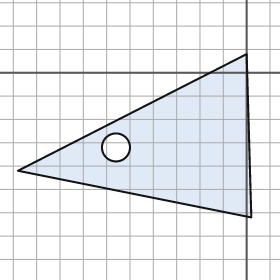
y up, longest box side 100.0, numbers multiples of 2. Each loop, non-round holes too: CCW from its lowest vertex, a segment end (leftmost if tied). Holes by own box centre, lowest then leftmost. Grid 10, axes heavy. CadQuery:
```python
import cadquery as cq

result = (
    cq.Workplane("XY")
    .moveTo(2.0, -62.0)
    .lineTo(0.0, 8.0)
    .lineTo(-98.0, -42.0)
    .close()
    .moveTo(-56.0, -32.0)
    .circle(6.0)
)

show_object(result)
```